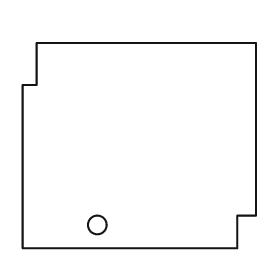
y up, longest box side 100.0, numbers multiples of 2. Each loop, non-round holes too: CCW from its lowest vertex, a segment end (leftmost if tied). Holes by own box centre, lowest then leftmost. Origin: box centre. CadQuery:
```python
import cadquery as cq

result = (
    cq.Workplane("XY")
    .moveTo(-50.0, -44.0)
    .lineTo(42.0, -44.0)
    .lineTo(42.0, -30.0)
    .lineTo(50.0, -30.0)
    .lineTo(50.0, 44.0)
    .lineTo(-44.0, 44.0)
    .lineTo(-44.0, 26.0)
    .lineTo(-50.0, 26.0)
    .close()
    .moveTo(-18.0, -34.0)
    .circle(4.0)
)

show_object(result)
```